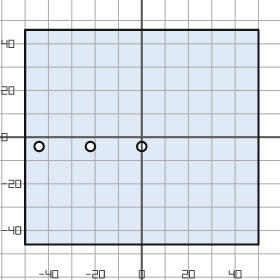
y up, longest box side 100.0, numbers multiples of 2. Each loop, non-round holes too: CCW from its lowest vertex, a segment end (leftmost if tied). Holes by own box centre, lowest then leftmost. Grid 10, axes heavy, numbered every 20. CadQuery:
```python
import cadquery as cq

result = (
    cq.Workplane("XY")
    .moveTo(-50.0, -46.0)
    .lineTo(50.0, -46.0)
    .lineTo(50.0, 46.0)
    .lineTo(-50.0, 46.0)
    .close()
    .moveTo(-44.0, -4.0)
    .circle(2.0)
    .moveTo(-22.0, -4.0)
    .circle(2.0)
    .moveTo(0.0, -4.0)
    .circle(2.0)
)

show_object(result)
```